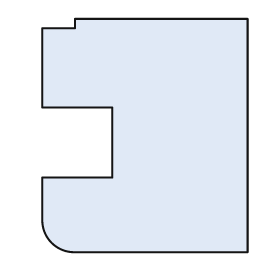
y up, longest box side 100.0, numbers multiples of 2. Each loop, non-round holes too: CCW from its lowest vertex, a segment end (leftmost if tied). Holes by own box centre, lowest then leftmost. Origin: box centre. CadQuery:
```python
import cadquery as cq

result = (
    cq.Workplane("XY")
    .moveTo(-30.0, -50.0)
    .lineTo(44.0, -50.0)
    .lineTo(44.0, 50.0)
    .lineTo(-30.0, 50.0)
    .lineTo(-30.0, 46.0)
    .lineTo(-44.0, 46.0)
    .lineTo(-44.0, 12.0)
    .lineTo(-14.0, 12.0)
    .lineTo(-14.0, -18.0)
    .lineTo(-44.0, -18.0)
    .lineTo(-44.0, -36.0)
    .threePointArc((-40.0, -46.0), (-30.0, -50.0))
    .close()
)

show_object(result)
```